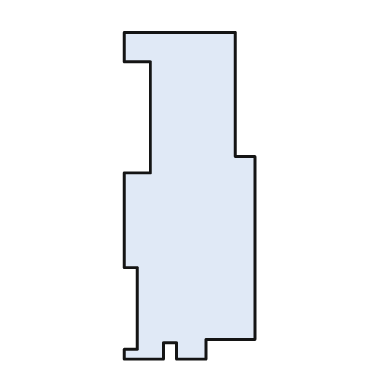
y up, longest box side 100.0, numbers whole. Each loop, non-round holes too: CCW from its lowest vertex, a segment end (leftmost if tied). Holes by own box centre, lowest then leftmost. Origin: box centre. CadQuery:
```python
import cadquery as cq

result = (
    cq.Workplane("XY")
    .moveTo(-20.0, -50.0)
    .lineTo(-8.0, -50.0)
    .lineTo(-8.0, -45.0)
    .lineTo(-4.0, -45.0)
    .lineTo(-4.0, -50.0)
    .lineTo(5.0, -50.0)
    .lineTo(5.0, -44.0)
    .lineTo(20.0, -44.0)
    .lineTo(20.0, 12.0)
    .lineTo(14.0, 12.0)
    .lineTo(14.0, 50.0)
    .lineTo(-20.0, 50.0)
    .lineTo(-20.0, 41.0)
    .lineTo(-12.0, 41.0)
    .lineTo(-12.0, 7.0)
    .lineTo(-20.0, 7.0)
    .lineTo(-20.0, -22.0)
    .lineTo(-16.0, -22.0)
    .lineTo(-16.0, -47.0)
    .lineTo(-20.0, -47.0)
    .close()
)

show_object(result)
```